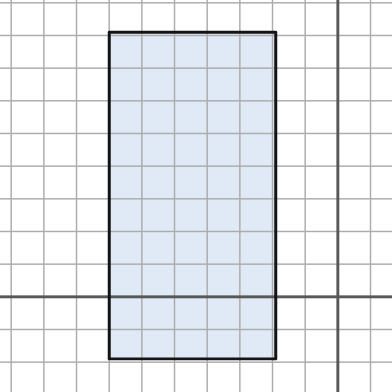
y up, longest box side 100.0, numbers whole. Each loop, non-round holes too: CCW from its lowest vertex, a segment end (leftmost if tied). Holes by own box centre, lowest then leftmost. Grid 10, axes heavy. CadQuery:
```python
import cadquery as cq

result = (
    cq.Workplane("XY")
    .moveTo(-70.0, -19.0)
    .lineTo(-19.0, -19.0)
    .lineTo(-19.0, 81.0)
    .lineTo(-70.0, 81.0)
    .close()
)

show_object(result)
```